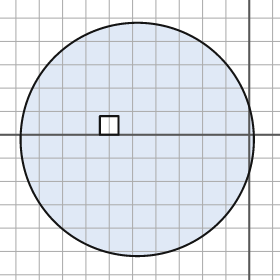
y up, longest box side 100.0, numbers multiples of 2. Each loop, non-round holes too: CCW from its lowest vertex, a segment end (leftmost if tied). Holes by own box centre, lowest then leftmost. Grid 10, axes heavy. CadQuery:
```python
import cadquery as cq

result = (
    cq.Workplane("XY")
    .moveTo(-48.0, -2.0)
    .circle(50.0)
    .moveTo(-64.0, 0.0)
    .lineTo(-56.0, 0.0)
    .lineTo(-56.0, 8.0)
    .lineTo(-64.0, 8.0)
    .close()
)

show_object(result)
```